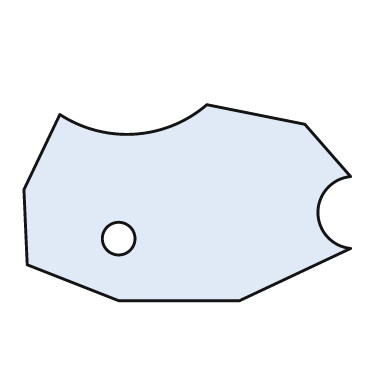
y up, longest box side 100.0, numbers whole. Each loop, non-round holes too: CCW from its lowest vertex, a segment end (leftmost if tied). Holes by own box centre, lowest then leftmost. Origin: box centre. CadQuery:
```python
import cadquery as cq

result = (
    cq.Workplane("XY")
    .moveTo(-21.0, -30.0)
    .lineTo(16.0, -30.0)
    .lineTo(50.0, -14.0)
    .threePointArc((40.0, -3.0), (50.0, 8.0))
    .lineTo(36.0, 24.0)
    .lineTo(6.0, 30.0)
    .threePointArc((-16.0, 21.0), (-39.0, 27.0))
    .lineTo(-50.0, 4.0)
    .lineTo(-49.0, -19.0)
    .close()
    .moveTo(-21.0, -11.0)
    .circle(5.0)
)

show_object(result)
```